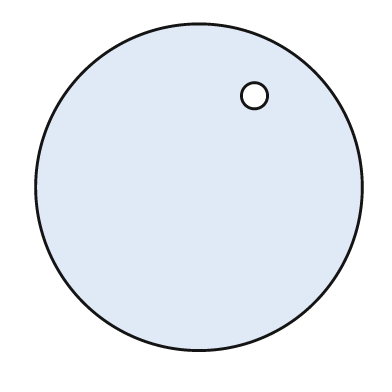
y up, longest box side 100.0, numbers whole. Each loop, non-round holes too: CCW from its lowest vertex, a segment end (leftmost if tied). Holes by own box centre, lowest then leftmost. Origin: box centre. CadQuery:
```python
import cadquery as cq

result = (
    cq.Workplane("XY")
    .moveTo(0.0, 0.0)
    .circle(50.0)
    .moveTo(17.0, 28.0)
    .circle(4.0)
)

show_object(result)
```